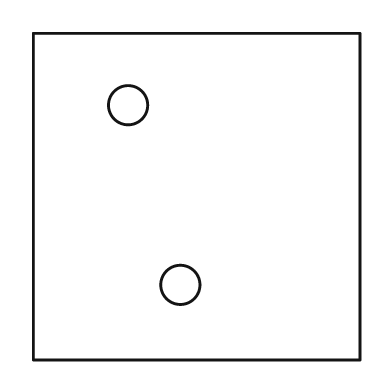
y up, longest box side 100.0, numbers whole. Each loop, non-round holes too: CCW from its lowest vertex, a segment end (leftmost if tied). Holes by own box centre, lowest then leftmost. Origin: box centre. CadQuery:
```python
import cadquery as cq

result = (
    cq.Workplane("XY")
    .moveTo(-50.0, -50.0)
    .lineTo(50.0, -50.0)
    .lineTo(50.0, 50.0)
    .lineTo(-50.0, 50.0)
    .close()
    .moveTo(-5.0, -27.0)
    .circle(6.0)
    .moveTo(-21.0, 28.0)
    .circle(6.0)
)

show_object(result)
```